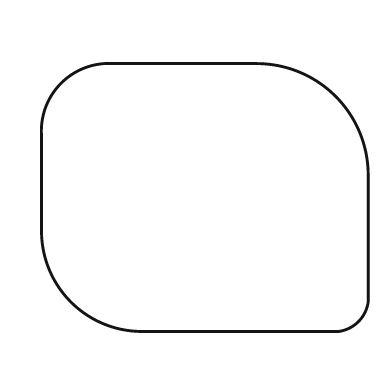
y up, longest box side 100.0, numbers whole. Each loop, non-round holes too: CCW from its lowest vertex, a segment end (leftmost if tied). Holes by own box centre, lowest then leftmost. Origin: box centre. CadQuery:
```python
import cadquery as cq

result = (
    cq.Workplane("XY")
    .moveTo(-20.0, -41.0)
    .lineTo(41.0, -41.0)
    .threePointArc((47.0, -38.0), (50.0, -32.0))
    .lineTo(50.0, 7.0)
    .threePointArc((40.0, 31.0), (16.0, 41.0))
    .lineTo(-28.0, 41.0)
    .threePointArc((-44.0, 35.0), (-50.0, 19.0))
    .lineTo(-50.0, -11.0)
    .threePointArc((-41.0, -32.0), (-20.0, -41.0))
    .close()
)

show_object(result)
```